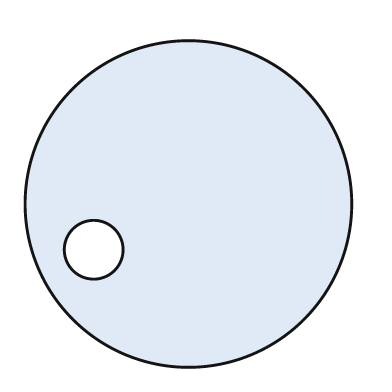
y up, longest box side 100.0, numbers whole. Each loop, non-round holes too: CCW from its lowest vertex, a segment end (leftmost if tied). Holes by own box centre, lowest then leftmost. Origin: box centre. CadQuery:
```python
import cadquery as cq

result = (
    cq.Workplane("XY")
    .moveTo(0.0, 0.0)
    .circle(50.0)
    .moveTo(-29.0, -14.0)
    .circle(9.0)
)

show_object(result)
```